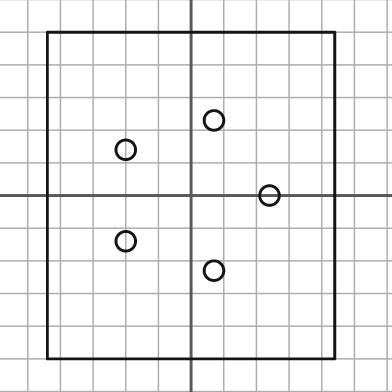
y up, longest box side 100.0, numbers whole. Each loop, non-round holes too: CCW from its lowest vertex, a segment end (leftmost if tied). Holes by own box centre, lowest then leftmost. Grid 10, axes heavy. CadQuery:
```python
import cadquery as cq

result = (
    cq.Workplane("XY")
    .moveTo(-44.0, -50.0)
    .lineTo(44.0, -50.0)
    .lineTo(44.0, 50.0)
    .lineTo(-44.0, 50.0)
    .close()
    .moveTo(7.0, -23.0)
    .circle(3.0)
    .moveTo(-20.0, -14.0)
    .circle(3.0)
    .moveTo(24.0, 0.0)
    .circle(3.0)
    .moveTo(-20.0, 14.0)
    .circle(3.0)
    .moveTo(7.0, 23.0)
    .circle(3.0)
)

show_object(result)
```